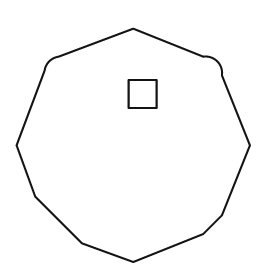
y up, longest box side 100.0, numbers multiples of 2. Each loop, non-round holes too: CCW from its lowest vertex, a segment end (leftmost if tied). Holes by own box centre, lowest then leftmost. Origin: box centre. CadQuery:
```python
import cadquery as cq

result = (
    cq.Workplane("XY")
    .moveTo(0.0, -50.0)
    .lineTo(30.0, -38.0)
    .lineTo(38.0, -30.0)
    .lineTo(50.0, 0.0)
    .lineTo(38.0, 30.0)
    .threePointArc((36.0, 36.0), (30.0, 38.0))
    .lineTo(0.0, 50.0)
    .lineTo(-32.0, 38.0)
    .threePointArc((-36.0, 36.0), (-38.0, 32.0))
    .lineTo(-50.0, 0.0)
    .lineTo(-42.0, -22.0)
    .lineTo(-22.0, -42.0)
    .close()
    .moveTo(-2.0, 16.0)
    .lineTo(10.0, 16.0)
    .lineTo(10.0, 28.0)
    .lineTo(-2.0, 28.0)
    .close()
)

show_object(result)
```